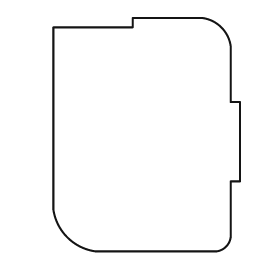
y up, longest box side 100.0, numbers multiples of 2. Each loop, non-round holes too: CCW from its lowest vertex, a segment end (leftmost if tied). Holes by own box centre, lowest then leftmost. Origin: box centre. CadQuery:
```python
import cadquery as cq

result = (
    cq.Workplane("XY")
    .moveTo(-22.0, -50.0)
    .lineTo(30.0, -50.0)
    .threePointArc((34.0, -48.0), (36.0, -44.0))
    .lineTo(36.0, -20.0)
    .lineTo(40.0, -20.0)
    .lineTo(40.0, 14.0)
    .lineTo(36.0, 14.0)
    .lineTo(36.0, 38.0)
    .threePointArc((32.0, 46.0), (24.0, 50.0))
    .lineTo(-6.0, 50.0)
    .lineTo(-6.0, 46.0)
    .lineTo(-40.0, 46.0)
    .lineTo(-40.0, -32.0)
    .threePointArc((-34.0, -44.0), (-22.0, -50.0))
    .close()
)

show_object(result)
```